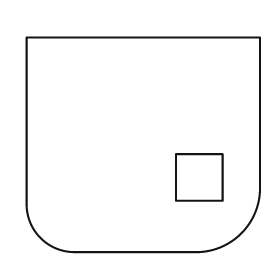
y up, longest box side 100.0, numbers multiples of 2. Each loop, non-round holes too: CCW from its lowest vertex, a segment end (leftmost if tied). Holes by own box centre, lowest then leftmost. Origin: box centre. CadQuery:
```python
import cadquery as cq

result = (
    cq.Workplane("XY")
    .moveTo(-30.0, -46.0)
    .lineTo(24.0, -46.0)
    .threePointArc((42.0, -38.0), (50.0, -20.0))
    .lineTo(50.0, 46.0)
    .lineTo(-50.0, 46.0)
    .lineTo(-50.0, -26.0)
    .threePointArc((-44.0, -40.0), (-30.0, -46.0))
    .close()
    .moveTo(14.0, -24.0)
    .lineTo(34.0, -24.0)
    .lineTo(34.0, -4.0)
    .lineTo(14.0, -4.0)
    .close()
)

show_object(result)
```